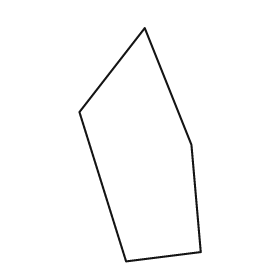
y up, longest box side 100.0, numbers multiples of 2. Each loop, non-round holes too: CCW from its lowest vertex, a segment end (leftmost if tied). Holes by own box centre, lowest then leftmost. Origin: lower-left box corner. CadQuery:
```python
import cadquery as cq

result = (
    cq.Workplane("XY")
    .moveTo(20.0, 0.0)
    .lineTo(52.0, 4.0)
    .lineTo(48.0, 50.0)
    .lineTo(28.0, 100.0)
    .lineTo(0.0, 64.0)
    .close()
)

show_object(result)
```